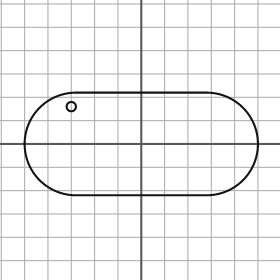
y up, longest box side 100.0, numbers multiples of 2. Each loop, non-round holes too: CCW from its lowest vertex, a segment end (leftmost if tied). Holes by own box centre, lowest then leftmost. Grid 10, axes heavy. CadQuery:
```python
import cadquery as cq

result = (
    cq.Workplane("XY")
    .moveTo(-28.0, -22.0)
    .lineTo(28.0, -22.0)
    .threePointArc((50.0, 0.0), (28.0, 22.0))
    .lineTo(-28.0, 22.0)
    .threePointArc((-50.0, 0.0), (-28.0, -22.0))
    .close()
    .moveTo(-30.0, 16.0)
    .circle(2.0)
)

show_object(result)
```